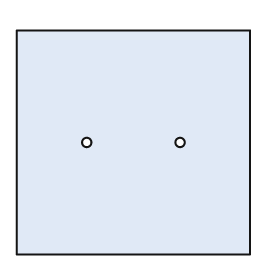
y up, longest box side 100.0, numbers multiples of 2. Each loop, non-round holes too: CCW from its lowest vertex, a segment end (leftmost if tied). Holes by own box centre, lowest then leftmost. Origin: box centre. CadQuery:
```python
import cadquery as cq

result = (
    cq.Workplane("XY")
    .moveTo(-50.0, -48.0)
    .lineTo(50.0, -48.0)
    .lineTo(50.0, 48.0)
    .lineTo(-50.0, 48.0)
    .close()
    .moveTo(-20.0, 0.0)
    .circle(2.0)
    .moveTo(20.0, 0.0)
    .circle(2.0)
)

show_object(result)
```